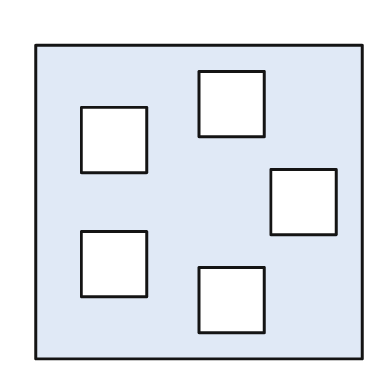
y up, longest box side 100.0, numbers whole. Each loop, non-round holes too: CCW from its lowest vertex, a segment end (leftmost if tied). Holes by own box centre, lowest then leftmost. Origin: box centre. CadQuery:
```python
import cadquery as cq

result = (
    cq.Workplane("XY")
    .moveTo(-50.0, -48.0)
    .lineTo(50.0, -48.0)
    .lineTo(50.0, 48.0)
    .lineTo(-50.0, 48.0)
    .close()
    .moveTo(0.0, -40.0)
    .lineTo(20.0, -40.0)
    .lineTo(20.0, -20.0)
    .lineTo(0.0, -20.0)
    .close()
    .moveTo(-36.0, -29.0)
    .lineTo(-16.0, -29.0)
    .lineTo(-16.0, -9.0)
    .lineTo(-36.0, -9.0)
    .close()
    .moveTo(22.0, -10.0)
    .lineTo(42.0, -10.0)
    .lineTo(42.0, 10.0)
    .lineTo(22.0, 10.0)
    .close()
    .moveTo(-36.0, 9.0)
    .lineTo(-16.0, 9.0)
    .lineTo(-16.0, 29.0)
    .lineTo(-36.0, 29.0)
    .close()
    .moveTo(0.0, 20.0)
    .lineTo(20.0, 20.0)
    .lineTo(20.0, 40.0)
    .lineTo(0.0, 40.0)
    .close()
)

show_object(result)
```